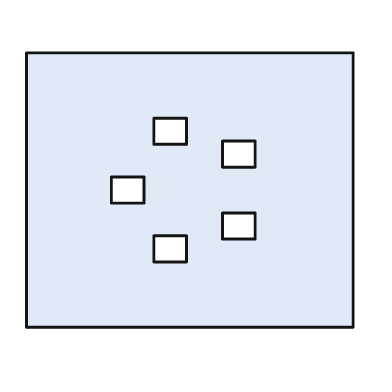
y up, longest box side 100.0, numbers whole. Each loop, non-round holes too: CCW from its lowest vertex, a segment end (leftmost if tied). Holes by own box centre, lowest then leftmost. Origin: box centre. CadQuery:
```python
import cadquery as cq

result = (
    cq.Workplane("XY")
    .moveTo(-50.0, -42.0)
    .lineTo(50.0, -42.0)
    .lineTo(50.0, 42.0)
    .lineTo(-50.0, 42.0)
    .close()
    .moveTo(-11.0, -22.0)
    .lineTo(-1.0, -22.0)
    .lineTo(-1.0, -14.0)
    .lineTo(-11.0, -14.0)
    .close()
    .moveTo(10.0, -15.0)
    .lineTo(20.0, -15.0)
    .lineTo(20.0, -7.0)
    .lineTo(10.0, -7.0)
    .close()
    .moveTo(-24.0, -4.0)
    .lineTo(-14.0, -4.0)
    .lineTo(-14.0, 4.0)
    .lineTo(-24.0, 4.0)
    .close()
    .moveTo(10.0, 7.0)
    .lineTo(20.0, 7.0)
    .lineTo(20.0, 15.0)
    .lineTo(10.0, 15.0)
    .close()
    .moveTo(-11.0, 14.0)
    .lineTo(-1.0, 14.0)
    .lineTo(-1.0, 22.0)
    .lineTo(-11.0, 22.0)
    .close()
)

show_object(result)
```